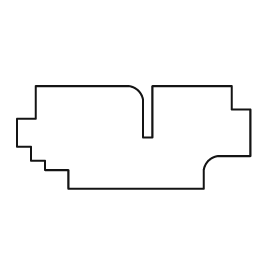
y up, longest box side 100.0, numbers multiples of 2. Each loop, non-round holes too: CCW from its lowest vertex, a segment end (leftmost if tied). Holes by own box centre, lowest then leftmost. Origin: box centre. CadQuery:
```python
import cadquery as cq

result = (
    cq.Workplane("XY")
    .moveTo(-28.0, -22.0)
    .lineTo(30.0, -22.0)
    .lineTo(30.0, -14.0)
    .threePointArc((32.0, -10.0), (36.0, -8.0))
    .lineTo(50.0, -8.0)
    .lineTo(50.0, 12.0)
    .lineTo(42.0, 12.0)
    .lineTo(42.0, 22.0)
    .lineTo(8.0, 22.0)
    .lineTo(8.0, 0.0)
    .lineTo(4.0, 0.0)
    .lineTo(4.0, 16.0)
    .threePointArc((2.0, 20.0), (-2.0, 22.0))
    .lineTo(-42.0, 22.0)
    .lineTo(-42.0, 8.0)
    .lineTo(-50.0, 8.0)
    .lineTo(-50.0, -4.0)
    .lineTo(-44.0, -4.0)
    .lineTo(-44.0, -10.0)
    .lineTo(-38.0, -10.0)
    .lineTo(-38.0, -14.0)
    .lineTo(-28.0, -14.0)
    .close()
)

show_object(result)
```